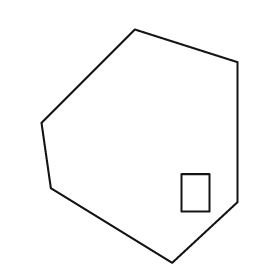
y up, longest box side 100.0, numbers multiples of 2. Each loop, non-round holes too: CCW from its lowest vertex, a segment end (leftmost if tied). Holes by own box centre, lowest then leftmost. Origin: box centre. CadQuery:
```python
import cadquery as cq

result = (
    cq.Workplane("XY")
    .moveTo(14.0, -50.0)
    .lineTo(42.0, -24.0)
    .lineTo(42.0, 36.0)
    .lineTo(-2.0, 50.0)
    .lineTo(-42.0, 10.0)
    .lineTo(-38.0, -18.0)
    .close()
    .moveTo(18.0, -28.0)
    .lineTo(30.0, -28.0)
    .lineTo(30.0, -12.0)
    .lineTo(18.0, -12.0)
    .close()
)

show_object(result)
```